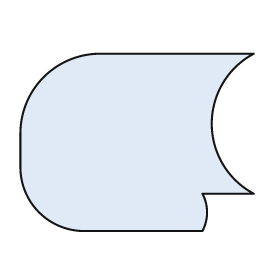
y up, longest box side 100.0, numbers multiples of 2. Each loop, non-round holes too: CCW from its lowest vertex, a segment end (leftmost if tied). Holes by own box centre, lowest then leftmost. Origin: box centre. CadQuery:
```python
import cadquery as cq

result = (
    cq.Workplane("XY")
    .moveTo(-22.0, -38.0)
    .lineTo(28.0, -38.0)
    .threePointArc((30.0, -30.0), (28.0, -22.0))
    .lineTo(50.0, -22.0)
    .threePointArc((32.0, 8.0), (50.0, 38.0))
    .lineTo(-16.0, 38.0)
    .threePointArc((-40.0, 28.0), (-50.0, 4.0))
    .lineTo(-50.0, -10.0)
    .threePointArc((-42.0, -30.0), (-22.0, -38.0))
    .close()
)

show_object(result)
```